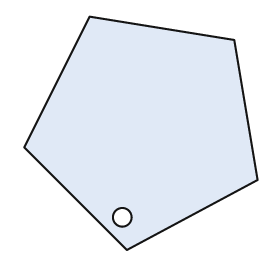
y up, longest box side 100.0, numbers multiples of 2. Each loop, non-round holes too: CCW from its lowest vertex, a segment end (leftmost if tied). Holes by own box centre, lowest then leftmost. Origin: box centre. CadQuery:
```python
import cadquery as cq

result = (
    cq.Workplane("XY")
    .moveTo(-6.0, -50.0)
    .lineTo(50.0, -20.0)
    .lineTo(40.0, 40.0)
    .lineTo(-22.0, 50.0)
    .lineTo(-50.0, -6.0)
    .close()
    .moveTo(-8.0, -36.0)
    .circle(4.0)
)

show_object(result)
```